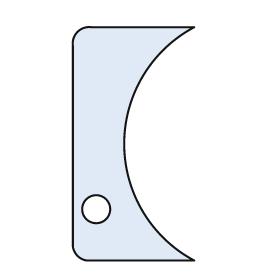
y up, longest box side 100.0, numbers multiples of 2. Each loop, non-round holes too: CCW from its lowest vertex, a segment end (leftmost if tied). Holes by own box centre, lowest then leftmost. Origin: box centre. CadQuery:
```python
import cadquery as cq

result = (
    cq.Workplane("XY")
    .moveTo(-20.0, -50.0)
    .lineTo(26.0, -50.0)
    .threePointArc((-4.0, 0.0), (26.0, 50.0))
    .lineTo(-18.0, 50.0)
    .threePointArc((-24.0, 48.0), (-26.0, 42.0))
    .lineTo(-26.0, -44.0)
    .threePointArc((-24.0, -48.0), (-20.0, -50.0))
    .close()
    .moveTo(-16.0, -28.0)
    .circle(6.0)
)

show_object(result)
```